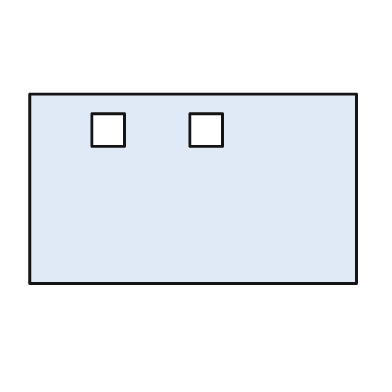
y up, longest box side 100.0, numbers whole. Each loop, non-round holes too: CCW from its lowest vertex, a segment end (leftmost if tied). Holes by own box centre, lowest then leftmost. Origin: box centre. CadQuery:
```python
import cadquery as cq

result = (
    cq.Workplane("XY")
    .moveTo(-50.0, -29.0)
    .lineTo(50.0, -29.0)
    .lineTo(50.0, 29.0)
    .lineTo(-50.0, 29.0)
    .close()
    .moveTo(-31.0, 13.0)
    .lineTo(-21.0, 13.0)
    .lineTo(-21.0, 23.0)
    .lineTo(-31.0, 23.0)
    .close()
    .moveTo(-1.0, 13.0)
    .lineTo(9.0, 13.0)
    .lineTo(9.0, 23.0)
    .lineTo(-1.0, 23.0)
    .close()
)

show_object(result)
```